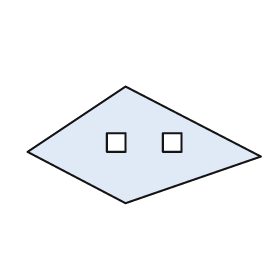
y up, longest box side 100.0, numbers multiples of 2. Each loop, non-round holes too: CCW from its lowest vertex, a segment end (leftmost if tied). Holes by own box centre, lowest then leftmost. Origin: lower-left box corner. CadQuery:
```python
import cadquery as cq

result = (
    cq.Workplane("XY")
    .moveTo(42.0, 0.0)
    .lineTo(100.0, 20.0)
    .lineTo(42.0, 50.0)
    .lineTo(0.0, 22.0)
    .close()
    .moveTo(34.0, 22.0)
    .lineTo(42.0, 22.0)
    .lineTo(42.0, 30.0)
    .lineTo(34.0, 30.0)
    .close()
    .moveTo(58.0, 22.0)
    .lineTo(66.0, 22.0)
    .lineTo(66.0, 30.0)
    .lineTo(58.0, 30.0)
    .close()
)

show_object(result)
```